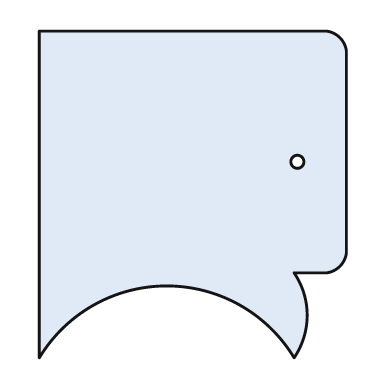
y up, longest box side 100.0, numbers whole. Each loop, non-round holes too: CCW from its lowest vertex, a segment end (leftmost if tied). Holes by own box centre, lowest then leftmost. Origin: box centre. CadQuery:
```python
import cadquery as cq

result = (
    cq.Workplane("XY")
    .moveTo(-47.0, -50.0)
    .threePointArc((-8.0, -28.0), (31.0, -50.0))
    .threePointArc((35.0, -37.0), (31.0, -24.0))
    .lineTo(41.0, -24.0)
    .threePointArc((45.0, -22.0), (47.0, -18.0))
    .lineTo(47.0, 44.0)
    .threePointArc((45.0, 48.0), (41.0, 50.0))
    .lineTo(-47.0, 50.0)
    .close()
    .moveTo(32.0, 10.0)
    .circle(2.0)
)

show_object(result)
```